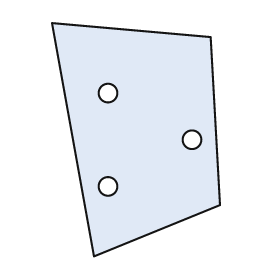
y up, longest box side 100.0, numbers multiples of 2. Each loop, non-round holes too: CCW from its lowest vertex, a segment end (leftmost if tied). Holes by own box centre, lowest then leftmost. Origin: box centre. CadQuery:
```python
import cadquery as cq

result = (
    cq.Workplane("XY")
    .moveTo(-18.0, -50.0)
    .lineTo(36.0, -28.0)
    .lineTo(32.0, 44.0)
    .lineTo(-36.0, 50.0)
    .close()
    .moveTo(-12.0, -20.0)
    .circle(4.0)
    .moveTo(24.0, 0.0)
    .circle(4.0)
    .moveTo(-12.0, 20.0)
    .circle(4.0)
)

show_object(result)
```